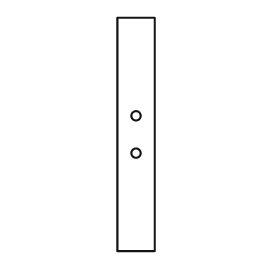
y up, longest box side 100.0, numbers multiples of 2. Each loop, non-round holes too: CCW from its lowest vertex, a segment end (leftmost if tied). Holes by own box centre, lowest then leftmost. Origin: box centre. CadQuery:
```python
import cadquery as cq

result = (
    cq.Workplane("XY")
    .moveTo(-8.0, -50.0)
    .lineTo(8.0, -50.0)
    .lineTo(8.0, 50.0)
    .lineTo(-8.0, 50.0)
    .close()
    .moveTo(0.0, -8.0)
    .circle(2.0)
    .moveTo(0.0, 8.0)
    .circle(2.0)
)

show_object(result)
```